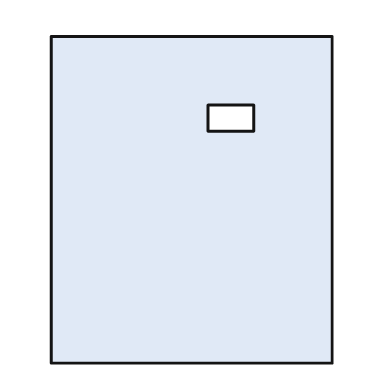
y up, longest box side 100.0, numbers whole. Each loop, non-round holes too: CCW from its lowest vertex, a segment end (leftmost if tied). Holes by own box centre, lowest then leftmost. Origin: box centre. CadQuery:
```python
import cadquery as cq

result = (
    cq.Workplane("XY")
    .moveTo(-43.0, -50.0)
    .lineTo(43.0, -50.0)
    .lineTo(43.0, 50.0)
    .lineTo(-43.0, 50.0)
    .close()
    .moveTo(5.0, 21.0)
    .lineTo(19.0, 21.0)
    .lineTo(19.0, 29.0)
    .lineTo(5.0, 29.0)
    .close()
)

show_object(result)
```